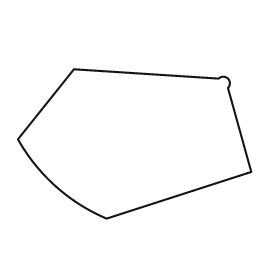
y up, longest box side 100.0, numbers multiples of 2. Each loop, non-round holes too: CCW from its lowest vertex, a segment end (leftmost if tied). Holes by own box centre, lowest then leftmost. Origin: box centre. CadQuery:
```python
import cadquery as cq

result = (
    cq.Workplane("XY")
    .moveTo(-12.0, -32.0)
    .lineTo(50.0, -12.0)
    .lineTo(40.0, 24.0)
    .threePointArc((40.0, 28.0), (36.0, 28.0))
    .lineTo(-26.0, 32.0)
    .lineTo(-50.0, 2.0)
    .threePointArc((-34.0, -18.0), (-12.0, -32.0))
    .close()
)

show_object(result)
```